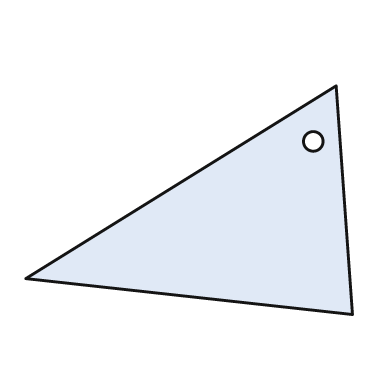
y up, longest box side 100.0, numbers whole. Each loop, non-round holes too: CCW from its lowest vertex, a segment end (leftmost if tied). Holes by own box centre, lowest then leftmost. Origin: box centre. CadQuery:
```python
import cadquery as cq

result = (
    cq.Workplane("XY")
    .moveTo(50.0, -35.0)
    .lineTo(45.0, 35.0)
    .lineTo(-50.0, -24.0)
    .close()
    .moveTo(38.0, 18.0)
    .circle(3.0)
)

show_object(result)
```